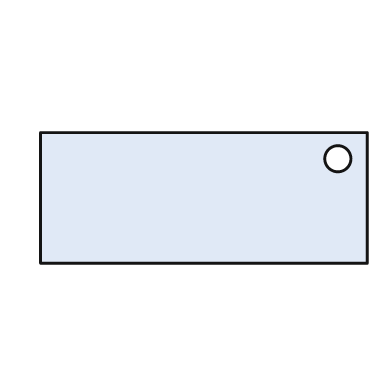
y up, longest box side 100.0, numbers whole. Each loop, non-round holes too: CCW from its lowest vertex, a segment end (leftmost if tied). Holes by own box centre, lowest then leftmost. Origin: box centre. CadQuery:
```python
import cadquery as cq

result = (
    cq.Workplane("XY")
    .moveTo(-50.0, -20.0)
    .lineTo(50.0, -20.0)
    .lineTo(50.0, 20.0)
    .lineTo(-50.0, 20.0)
    .close()
    .moveTo(41.0, 12.0)
    .circle(4.0)
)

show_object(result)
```